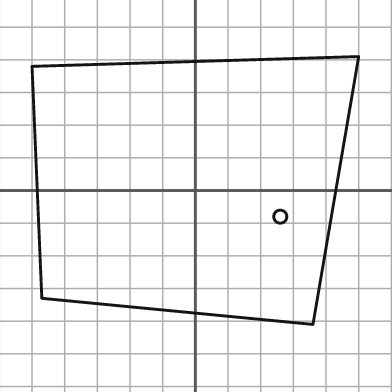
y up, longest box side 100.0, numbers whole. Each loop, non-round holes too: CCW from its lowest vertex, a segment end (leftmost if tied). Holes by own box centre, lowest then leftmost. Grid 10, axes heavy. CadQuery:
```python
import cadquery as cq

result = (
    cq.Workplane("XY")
    .moveTo(36.0, -41.0)
    .lineTo(50.0, 41.0)
    .lineTo(-50.0, 38.0)
    .lineTo(-47.0, -33.0)
    .close()
    .moveTo(26.0, -8.0)
    .circle(2.0)
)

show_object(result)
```